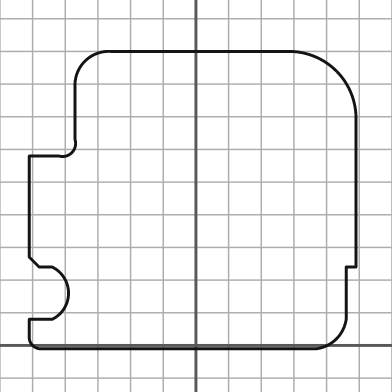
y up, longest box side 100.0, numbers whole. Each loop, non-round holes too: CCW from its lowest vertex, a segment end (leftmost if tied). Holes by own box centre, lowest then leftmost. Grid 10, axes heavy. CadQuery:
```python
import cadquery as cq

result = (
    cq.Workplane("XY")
    .moveTo(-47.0, -1.0)
    .lineTo(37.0, -1.0)
    .threePointArc((43.0, 2.0), (46.0, 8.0))
    .lineTo(46.0, 24.0)
    .lineTo(49.0, 24.0)
    .lineTo(49.0, 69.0)
    .threePointArc((43.0, 84.0), (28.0, 90.0))
    .lineTo(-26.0, 90.0)
    .threePointArc((-34.0, 87.0), (-37.0, 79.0))
    .lineTo(-37.0, 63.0)
    .threePointArc((-38.0, 59.0), (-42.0, 58.0))
    .lineTo(-51.0, 58.0)
    .lineTo(-51.0, 27.0)
    .lineTo(-48.0, 24.0)
    .lineTo(-44.0, 24.0)
    .threePointArc((-39.0, 16.0), (-44.0, 8.0))
    .lineTo(-51.0, 8.0)
    .lineTo(-51.0, 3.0)
    .threePointArc((-50.0, 0.0), (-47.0, -1.0))
    .close()
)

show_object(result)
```